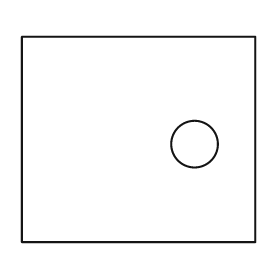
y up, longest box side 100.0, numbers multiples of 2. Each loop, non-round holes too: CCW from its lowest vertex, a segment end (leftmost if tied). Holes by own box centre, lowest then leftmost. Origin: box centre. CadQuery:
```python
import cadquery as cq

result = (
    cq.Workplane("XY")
    .moveTo(-50.0, -44.0)
    .lineTo(50.0, -44.0)
    .lineTo(50.0, 44.0)
    .lineTo(-50.0, 44.0)
    .close()
    .moveTo(24.0, -2.0)
    .circle(10.0)
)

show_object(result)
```